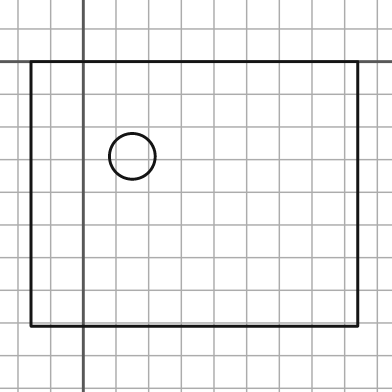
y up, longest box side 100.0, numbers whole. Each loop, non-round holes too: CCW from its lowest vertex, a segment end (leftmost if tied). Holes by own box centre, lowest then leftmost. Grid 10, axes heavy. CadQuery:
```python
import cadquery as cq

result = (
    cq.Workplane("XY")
    .moveTo(-16.0, -81.0)
    .lineTo(84.0, -81.0)
    .lineTo(84.0, 0.0)
    .lineTo(-16.0, 0.0)
    .close()
    .moveTo(15.0, -29.0)
    .circle(7.0)
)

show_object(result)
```